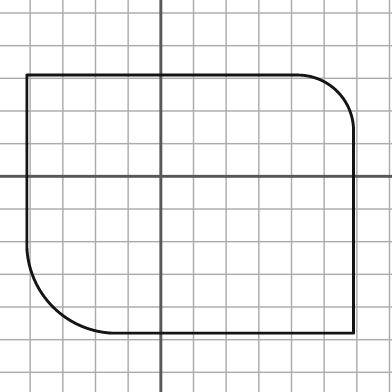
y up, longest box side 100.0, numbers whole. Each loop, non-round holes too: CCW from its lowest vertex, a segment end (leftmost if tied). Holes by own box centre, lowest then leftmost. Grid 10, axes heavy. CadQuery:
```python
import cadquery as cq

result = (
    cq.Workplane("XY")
    .moveTo(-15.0, -48.0)
    .lineTo(59.0, -48.0)
    .lineTo(59.0, 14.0)
    .threePointArc((54.0, 26.0), (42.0, 31.0))
    .lineTo(-41.0, 31.0)
    .lineTo(-41.0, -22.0)
    .threePointArc((-33.0, -40.0), (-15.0, -48.0))
    .close()
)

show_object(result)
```